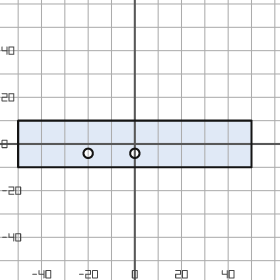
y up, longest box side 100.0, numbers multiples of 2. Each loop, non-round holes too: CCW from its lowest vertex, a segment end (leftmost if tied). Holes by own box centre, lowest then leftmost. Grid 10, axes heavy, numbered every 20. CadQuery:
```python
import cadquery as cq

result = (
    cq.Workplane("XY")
    .moveTo(-50.0, -10.0)
    .lineTo(50.0, -10.0)
    .lineTo(50.0, 10.0)
    .lineTo(-50.0, 10.0)
    .close()
    .moveTo(-20.0, -4.0)
    .circle(2.0)
    .moveTo(0.0, -4.0)
    .circle(2.0)
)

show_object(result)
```